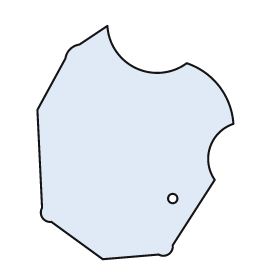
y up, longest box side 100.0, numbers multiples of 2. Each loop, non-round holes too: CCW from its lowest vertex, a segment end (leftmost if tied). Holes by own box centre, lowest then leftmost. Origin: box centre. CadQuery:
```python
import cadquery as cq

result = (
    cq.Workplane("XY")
    .moveTo(-14.0, -50.0)
    .lineTo(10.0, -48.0)
    .threePointArc((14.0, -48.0), (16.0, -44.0))
    .lineTo(34.0, -16.0)
    .threePointArc((32.0, -2.0), (42.0, 8.0))
    .threePointArc((36.0, 24.0), (22.0, 34.0))
    .threePointArc((0.0, 32.0), (-12.0, 50.0))
    .lineTo(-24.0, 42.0)
    .threePointArc((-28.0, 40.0), (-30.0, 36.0))
    .lineTo(-42.0, 14.0)
    .lineTo(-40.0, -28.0)
    .threePointArc((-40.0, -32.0), (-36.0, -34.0))
    .close()
    .moveTo(16.0, -24.0)
    .circle(2.0)
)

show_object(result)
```